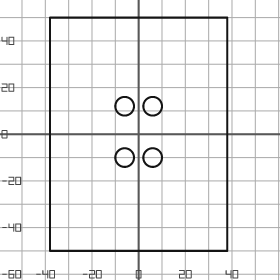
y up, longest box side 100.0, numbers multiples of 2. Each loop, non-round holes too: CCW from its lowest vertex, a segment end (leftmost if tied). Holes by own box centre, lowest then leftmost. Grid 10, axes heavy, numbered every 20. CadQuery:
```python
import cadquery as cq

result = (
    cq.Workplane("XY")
    .moveTo(-38.0, -50.0)
    .lineTo(38.0, -50.0)
    .lineTo(38.0, 50.0)
    .lineTo(-38.0, 50.0)
    .close()
    .moveTo(-6.0, -10.0)
    .circle(4.0)
    .moveTo(6.0, -10.0)
    .circle(4.0)
    .moveTo(-6.0, 12.0)
    .circle(4.0)
    .moveTo(6.0, 12.0)
    .circle(4.0)
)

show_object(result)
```